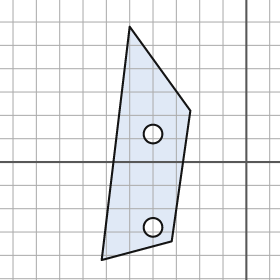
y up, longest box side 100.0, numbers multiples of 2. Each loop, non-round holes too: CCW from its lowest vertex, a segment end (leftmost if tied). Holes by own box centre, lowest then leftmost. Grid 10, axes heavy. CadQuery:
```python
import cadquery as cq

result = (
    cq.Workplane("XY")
    .moveTo(-62.0, -42.0)
    .lineTo(-32.0, -34.0)
    .lineTo(-24.0, 22.0)
    .lineTo(-50.0, 58.0)
    .close()
    .moveTo(-40.0, -28.0)
    .circle(4.0)
    .moveTo(-40.0, 12.0)
    .circle(4.0)
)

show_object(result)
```